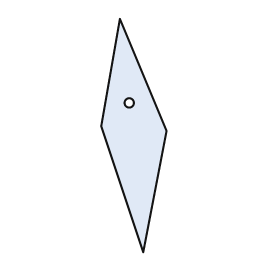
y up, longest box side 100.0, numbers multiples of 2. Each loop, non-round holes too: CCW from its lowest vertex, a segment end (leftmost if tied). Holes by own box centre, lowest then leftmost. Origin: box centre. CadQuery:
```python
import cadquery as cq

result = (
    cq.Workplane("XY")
    .moveTo(4.0, -50.0)
    .lineTo(14.0, 2.0)
    .lineTo(-6.0, 50.0)
    .lineTo(-14.0, 4.0)
    .close()
    .moveTo(-2.0, 14.0)
    .circle(2.0)
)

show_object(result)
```